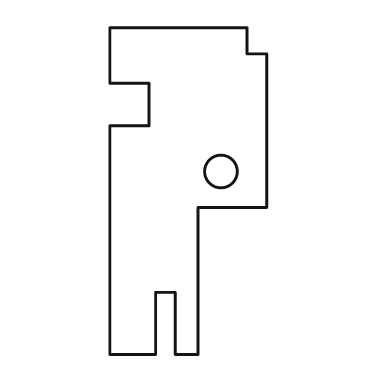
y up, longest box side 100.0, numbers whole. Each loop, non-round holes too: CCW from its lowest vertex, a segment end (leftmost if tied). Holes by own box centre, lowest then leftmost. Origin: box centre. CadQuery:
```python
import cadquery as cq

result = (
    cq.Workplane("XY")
    .moveTo(-24.0, -50.0)
    .lineTo(-10.0, -50.0)
    .lineTo(-10.0, -31.0)
    .lineTo(-4.0, -31.0)
    .lineTo(-4.0, -50.0)
    .lineTo(3.0, -50.0)
    .lineTo(3.0, -5.0)
    .lineTo(24.0, -5.0)
    .lineTo(24.0, 42.0)
    .lineTo(18.0, 42.0)
    .lineTo(18.0, 50.0)
    .lineTo(-24.0, 50.0)
    .lineTo(-24.0, 33.0)
    .lineTo(-12.0, 33.0)
    .lineTo(-12.0, 20.0)
    .lineTo(-24.0, 20.0)
    .close()
    .moveTo(10.0, 6.0)
    .circle(5.0)
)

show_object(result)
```